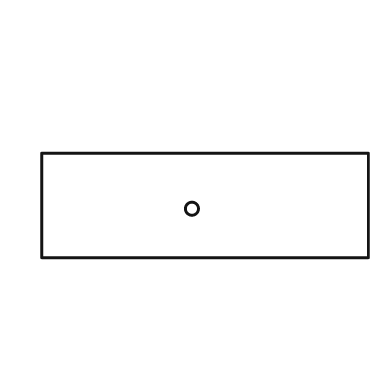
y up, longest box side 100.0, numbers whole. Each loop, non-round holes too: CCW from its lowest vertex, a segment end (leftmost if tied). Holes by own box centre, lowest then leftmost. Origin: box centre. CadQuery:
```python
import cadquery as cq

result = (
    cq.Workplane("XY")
    .moveTo(-50.0, -16.0)
    .lineTo(50.0, -16.0)
    .lineTo(50.0, 16.0)
    .lineTo(-50.0, 16.0)
    .close()
    .moveTo(-4.0, -1.0)
    .circle(2.0)
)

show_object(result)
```